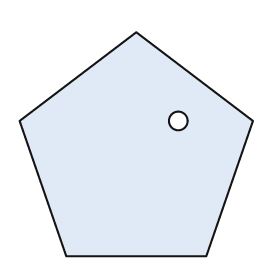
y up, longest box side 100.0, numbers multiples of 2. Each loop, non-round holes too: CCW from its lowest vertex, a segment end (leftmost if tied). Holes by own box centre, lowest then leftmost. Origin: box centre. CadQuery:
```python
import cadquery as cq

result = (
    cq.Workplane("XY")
    .moveTo(-30.0, -48.0)
    .lineTo(30.0, -48.0)
    .lineTo(50.0, 10.0)
    .lineTo(0.0, 48.0)
    .lineTo(-50.0, 10.0)
    .close()
    .moveTo(18.0, 10.0)
    .circle(4.0)
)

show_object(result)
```